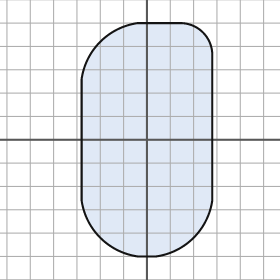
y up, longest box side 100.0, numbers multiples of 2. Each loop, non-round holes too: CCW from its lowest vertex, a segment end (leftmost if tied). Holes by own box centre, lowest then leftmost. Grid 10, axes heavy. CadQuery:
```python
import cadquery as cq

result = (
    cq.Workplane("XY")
    .moveTo(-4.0, -50.0)
    .lineTo(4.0, -50.0)
    .threePointArc((20.0, -42.0), (28.0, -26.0))
    .lineTo(28.0, 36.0)
    .threePointArc((24.0, 46.0), (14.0, 50.0))
    .lineTo(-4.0, 50.0)
    .threePointArc((-20.0, 42.0), (-28.0, 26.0))
    .lineTo(-28.0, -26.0)
    .threePointArc((-20.0, -42.0), (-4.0, -50.0))
    .close()
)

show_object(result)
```